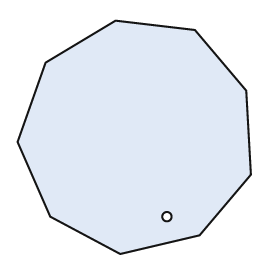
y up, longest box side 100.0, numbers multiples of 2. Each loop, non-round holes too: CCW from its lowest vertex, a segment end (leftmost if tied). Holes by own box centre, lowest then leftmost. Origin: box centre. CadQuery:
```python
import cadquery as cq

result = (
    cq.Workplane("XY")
    .moveTo(-6.0, -50.0)
    .lineTo(28.0, -42.0)
    .lineTo(50.0, -16.0)
    .lineTo(48.0, 20.0)
    .lineTo(26.0, 46.0)
    .lineTo(-8.0, 50.0)
    .lineTo(-38.0, 32.0)
    .lineTo(-50.0, -2.0)
    .lineTo(-36.0, -34.0)
    .close()
    .moveTo(14.0, -34.0)
    .circle(2.0)
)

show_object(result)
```